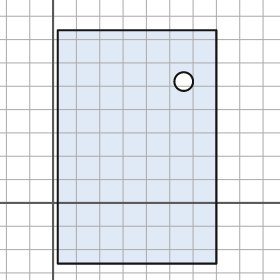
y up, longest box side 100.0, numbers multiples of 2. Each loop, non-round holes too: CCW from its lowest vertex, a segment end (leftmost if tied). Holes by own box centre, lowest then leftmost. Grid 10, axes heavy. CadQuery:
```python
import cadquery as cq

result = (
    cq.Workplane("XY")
    .moveTo(2.0, -26.0)
    .lineTo(70.0, -26.0)
    .lineTo(70.0, 74.0)
    .lineTo(2.0, 74.0)
    .close()
    .moveTo(56.0, 52.0)
    .circle(4.0)
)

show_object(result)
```